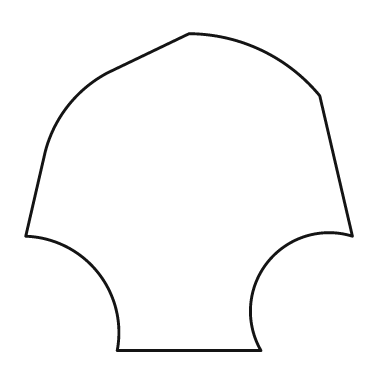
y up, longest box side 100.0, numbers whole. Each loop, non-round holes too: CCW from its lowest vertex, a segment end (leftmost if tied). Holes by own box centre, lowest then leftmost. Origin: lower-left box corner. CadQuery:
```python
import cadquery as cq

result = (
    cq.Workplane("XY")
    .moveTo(28.0, 0.0)
    .lineTo(72.0, 0.0)
    .threePointArc((74.0, 27.0), (100.0, 35.0))
    .lineTo(90.0, 78.0)
    .threePointArc((72.0, 92.0), (50.0, 97.0))
    .lineTo(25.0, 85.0)
    .threePointArc((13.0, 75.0), (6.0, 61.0))
    .lineTo(0.0, 35.0)
    .threePointArc((22.0, 24.0), (28.0, 0.0))
    .close()
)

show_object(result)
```